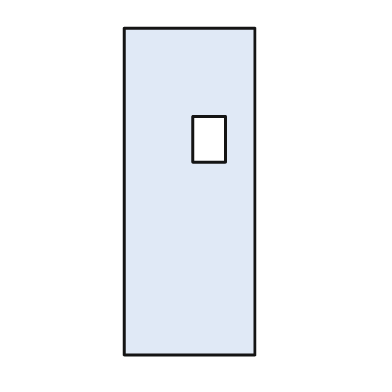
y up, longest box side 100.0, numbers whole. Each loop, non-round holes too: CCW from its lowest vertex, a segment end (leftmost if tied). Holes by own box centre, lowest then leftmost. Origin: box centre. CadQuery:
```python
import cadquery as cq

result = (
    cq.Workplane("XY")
    .moveTo(-20.0, -50.0)
    .lineTo(20.0, -50.0)
    .lineTo(20.0, 50.0)
    .lineTo(-20.0, 50.0)
    .close()
    .moveTo(1.0, 9.0)
    .lineTo(11.0, 9.0)
    .lineTo(11.0, 23.0)
    .lineTo(1.0, 23.0)
    .close()
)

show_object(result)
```